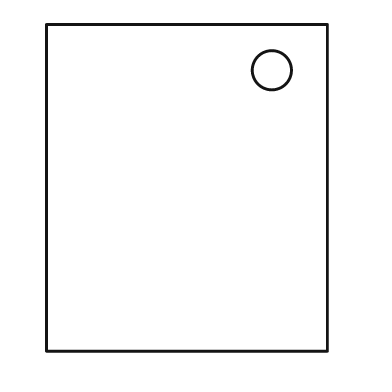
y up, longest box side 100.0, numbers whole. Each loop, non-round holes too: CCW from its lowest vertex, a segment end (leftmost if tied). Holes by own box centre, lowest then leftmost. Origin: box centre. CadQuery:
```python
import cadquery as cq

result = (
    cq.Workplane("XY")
    .moveTo(-43.0, -50.0)
    .lineTo(43.0, -50.0)
    .lineTo(43.0, 50.0)
    .lineTo(-43.0, 50.0)
    .close()
    .moveTo(26.0, 36.0)
    .circle(6.0)
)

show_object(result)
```